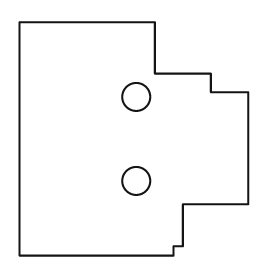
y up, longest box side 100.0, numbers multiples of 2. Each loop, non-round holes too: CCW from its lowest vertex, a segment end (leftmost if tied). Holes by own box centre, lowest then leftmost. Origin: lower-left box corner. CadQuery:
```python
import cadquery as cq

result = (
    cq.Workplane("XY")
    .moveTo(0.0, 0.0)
    .lineTo(66.0, 0.0)
    .lineTo(66.0, 4.0)
    .lineTo(70.0, 4.0)
    .lineTo(70.0, 22.0)
    .lineTo(98.0, 22.0)
    .lineTo(98.0, 70.0)
    .lineTo(82.0, 70.0)
    .lineTo(82.0, 78.0)
    .lineTo(58.0, 78.0)
    .lineTo(58.0, 100.0)
    .lineTo(0.0, 100.0)
    .close()
    .moveTo(50.0, 32.0)
    .circle(6.0)
    .moveTo(50.0, 68.0)
    .circle(6.0)
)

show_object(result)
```